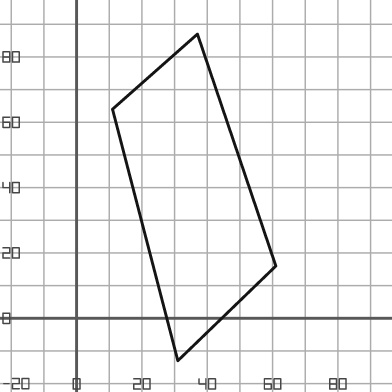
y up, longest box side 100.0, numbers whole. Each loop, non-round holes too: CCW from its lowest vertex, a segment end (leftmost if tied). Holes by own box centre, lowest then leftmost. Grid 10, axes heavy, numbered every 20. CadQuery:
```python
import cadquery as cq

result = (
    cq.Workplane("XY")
    .moveTo(31.0, -13.0)
    .lineTo(61.0, 16.0)
    .lineTo(37.0, 87.0)
    .lineTo(11.0, 64.0)
    .close()
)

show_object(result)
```